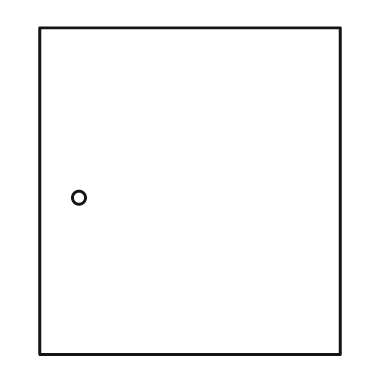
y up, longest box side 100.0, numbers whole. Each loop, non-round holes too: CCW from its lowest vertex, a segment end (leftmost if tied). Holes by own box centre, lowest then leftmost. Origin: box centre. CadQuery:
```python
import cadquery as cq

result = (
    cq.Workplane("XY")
    .moveTo(-46.0, -50.0)
    .lineTo(46.0, -50.0)
    .lineTo(46.0, 50.0)
    .lineTo(-46.0, 50.0)
    .close()
    .moveTo(-34.0, -2.0)
    .circle(2.0)
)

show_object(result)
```